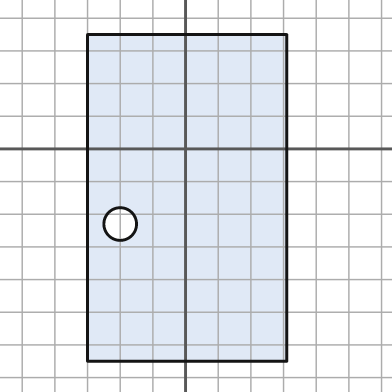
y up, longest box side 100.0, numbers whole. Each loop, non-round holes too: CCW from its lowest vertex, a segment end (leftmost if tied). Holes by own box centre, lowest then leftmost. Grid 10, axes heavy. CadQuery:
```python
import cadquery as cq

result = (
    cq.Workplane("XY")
    .moveTo(-30.0, -65.0)
    .lineTo(31.0, -65.0)
    .lineTo(31.0, 35.0)
    .lineTo(-30.0, 35.0)
    .close()
    .moveTo(-20.0, -23.0)
    .circle(5.0)
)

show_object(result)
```